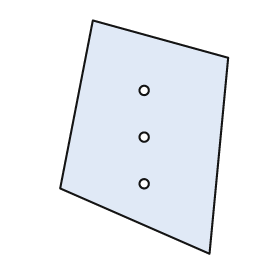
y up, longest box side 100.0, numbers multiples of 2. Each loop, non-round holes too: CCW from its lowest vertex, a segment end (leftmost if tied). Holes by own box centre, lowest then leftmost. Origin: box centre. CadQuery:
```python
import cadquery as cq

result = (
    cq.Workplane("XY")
    .moveTo(28.0, -50.0)
    .lineTo(36.0, 34.0)
    .lineTo(-22.0, 50.0)
    .lineTo(-36.0, -22.0)
    .close()
    .moveTo(0.0, -20.0)
    .circle(2.0)
    .moveTo(0.0, 0.0)
    .circle(2.0)
    .moveTo(0.0, 20.0)
    .circle(2.0)
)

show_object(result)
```